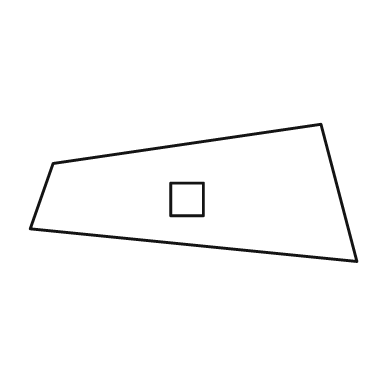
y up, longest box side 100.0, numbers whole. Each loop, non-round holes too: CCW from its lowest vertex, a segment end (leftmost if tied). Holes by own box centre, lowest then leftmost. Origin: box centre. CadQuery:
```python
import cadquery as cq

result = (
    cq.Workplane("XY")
    .moveTo(50.0, -21.0)
    .lineTo(39.0, 21.0)
    .lineTo(-43.0, 9.0)
    .lineTo(-50.0, -11.0)
    .close()
    .moveTo(-7.0, -7.0)
    .lineTo(3.0, -7.0)
    .lineTo(3.0, 3.0)
    .lineTo(-7.0, 3.0)
    .close()
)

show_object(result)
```